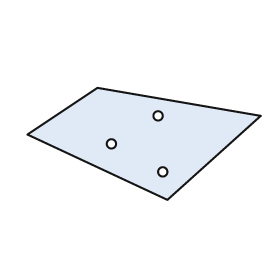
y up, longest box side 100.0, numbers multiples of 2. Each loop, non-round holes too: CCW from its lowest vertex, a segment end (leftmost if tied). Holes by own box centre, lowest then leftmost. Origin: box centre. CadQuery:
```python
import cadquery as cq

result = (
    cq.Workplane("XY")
    .moveTo(10.0, -24.0)
    .lineTo(50.0, 12.0)
    .lineTo(-20.0, 24.0)
    .lineTo(-50.0, 4.0)
    .close()
    .moveTo(8.0, -12.0)
    .circle(2.0)
    .moveTo(-14.0, 0.0)
    .circle(2.0)
    .moveTo(6.0, 12.0)
    .circle(2.0)
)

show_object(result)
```